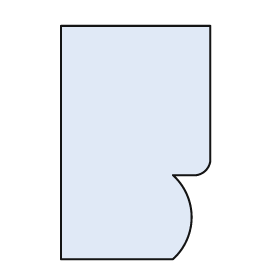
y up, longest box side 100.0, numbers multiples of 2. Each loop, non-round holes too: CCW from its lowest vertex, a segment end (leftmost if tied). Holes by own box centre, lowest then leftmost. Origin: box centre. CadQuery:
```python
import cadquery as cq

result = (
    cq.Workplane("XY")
    .moveTo(-32.0, -50.0)
    .lineTo(16.0, -50.0)
    .threePointArc((24.0, -32.0), (16.0, -14.0))
    .lineTo(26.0, -14.0)
    .threePointArc((30.0, -12.0), (32.0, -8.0))
    .lineTo(32.0, 50.0)
    .lineTo(-32.0, 50.0)
    .close()
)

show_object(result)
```